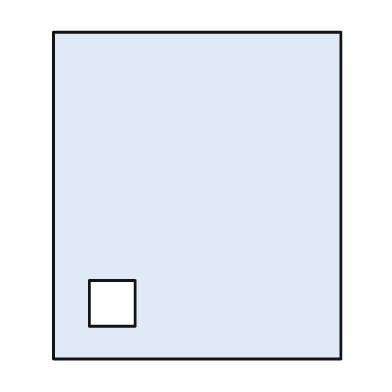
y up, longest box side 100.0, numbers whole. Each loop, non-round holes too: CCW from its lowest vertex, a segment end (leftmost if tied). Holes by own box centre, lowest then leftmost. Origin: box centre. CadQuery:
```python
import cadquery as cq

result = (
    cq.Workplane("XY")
    .moveTo(-44.0, -50.0)
    .lineTo(44.0, -50.0)
    .lineTo(44.0, 50.0)
    .lineTo(-44.0, 50.0)
    .close()
    .moveTo(-33.0, -40.0)
    .lineTo(-19.0, -40.0)
    .lineTo(-19.0, -26.0)
    .lineTo(-33.0, -26.0)
    .close()
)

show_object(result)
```